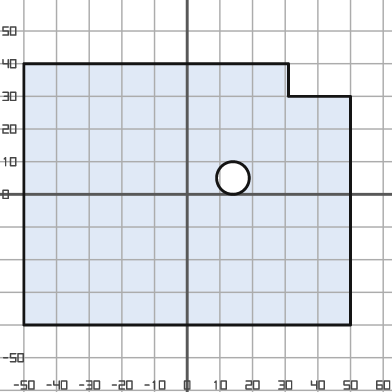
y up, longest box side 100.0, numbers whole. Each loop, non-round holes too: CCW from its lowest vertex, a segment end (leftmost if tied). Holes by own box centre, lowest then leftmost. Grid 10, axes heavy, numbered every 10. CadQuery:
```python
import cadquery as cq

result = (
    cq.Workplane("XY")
    .moveTo(-50.0, -40.0)
    .lineTo(50.0, -40.0)
    .lineTo(50.0, 30.0)
    .lineTo(31.0, 30.0)
    .lineTo(31.0, 40.0)
    .lineTo(-50.0, 40.0)
    .close()
    .moveTo(14.0, 5.0)
    .circle(5.0)
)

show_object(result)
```